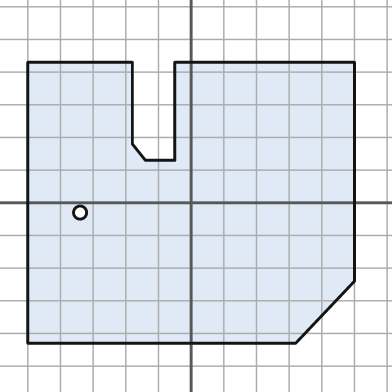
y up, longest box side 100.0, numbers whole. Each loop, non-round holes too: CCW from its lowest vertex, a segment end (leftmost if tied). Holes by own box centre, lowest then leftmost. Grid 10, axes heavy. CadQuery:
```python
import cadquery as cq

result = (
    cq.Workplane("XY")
    .moveTo(-50.0, -43.0)
    .lineTo(32.0, -43.0)
    .lineTo(50.0, -24.0)
    .lineTo(50.0, 43.0)
    .lineTo(-5.0, 43.0)
    .lineTo(-5.0, 13.0)
    .lineTo(-14.0, 13.0)
    .lineTo(-18.0, 18.0)
    .lineTo(-18.0, 43.0)
    .lineTo(-50.0, 43.0)
    .close()
    .moveTo(-34.0, -3.0)
    .circle(2.0)
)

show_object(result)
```